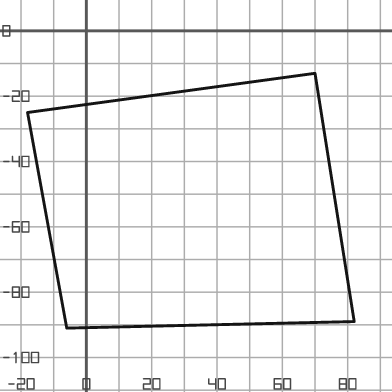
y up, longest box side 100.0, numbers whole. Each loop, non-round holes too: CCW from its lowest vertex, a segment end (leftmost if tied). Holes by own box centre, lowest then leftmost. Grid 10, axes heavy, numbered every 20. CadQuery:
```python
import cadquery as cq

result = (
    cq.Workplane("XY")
    .moveTo(-6.0, -91.0)
    .lineTo(82.0, -89.0)
    .lineTo(70.0, -13.0)
    .lineTo(-18.0, -25.0)
    .close()
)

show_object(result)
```